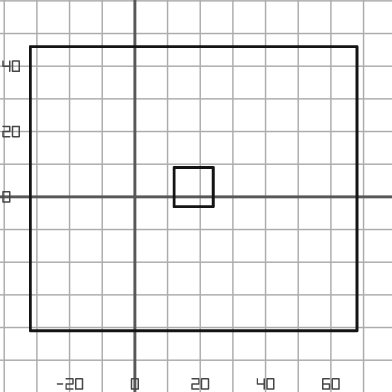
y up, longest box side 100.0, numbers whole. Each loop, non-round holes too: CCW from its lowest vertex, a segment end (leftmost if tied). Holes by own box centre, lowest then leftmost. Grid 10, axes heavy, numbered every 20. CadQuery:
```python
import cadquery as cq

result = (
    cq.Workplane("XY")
    .moveTo(-32.0, -41.0)
    .lineTo(68.0, -41.0)
    .lineTo(68.0, 46.0)
    .lineTo(-32.0, 46.0)
    .close()
    .moveTo(12.0, -3.0)
    .lineTo(24.0, -3.0)
    .lineTo(24.0, 9.0)
    .lineTo(12.0, 9.0)
    .close()
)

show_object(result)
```